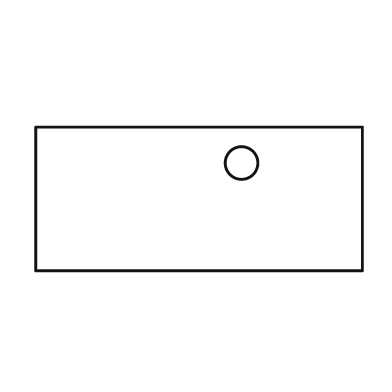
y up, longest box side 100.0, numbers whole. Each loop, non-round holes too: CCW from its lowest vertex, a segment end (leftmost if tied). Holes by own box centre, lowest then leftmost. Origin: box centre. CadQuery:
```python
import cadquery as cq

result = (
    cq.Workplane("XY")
    .moveTo(-50.0, -22.0)
    .lineTo(50.0, -22.0)
    .lineTo(50.0, 22.0)
    .lineTo(-50.0, 22.0)
    .close()
    .moveTo(13.0, 11.0)
    .circle(5.0)
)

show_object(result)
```